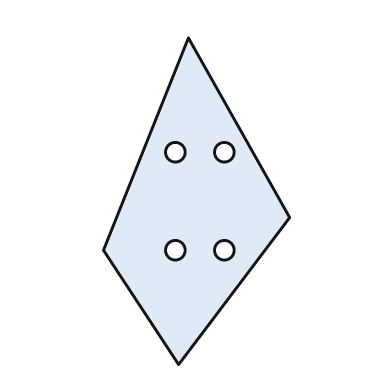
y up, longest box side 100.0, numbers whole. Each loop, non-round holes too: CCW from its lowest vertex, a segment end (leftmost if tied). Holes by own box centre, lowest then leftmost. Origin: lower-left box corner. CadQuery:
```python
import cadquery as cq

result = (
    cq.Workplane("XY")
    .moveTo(23.0, 0.0)
    .lineTo(57.0, 45.0)
    .lineTo(26.0, 100.0)
    .lineTo(0.0, 35.0)
    .close()
    .moveTo(22.0, 35.0)
    .circle(3.0)
    .moveTo(37.0, 35.0)
    .circle(3.0)
    .moveTo(22.0, 65.0)
    .circle(3.0)
    .moveTo(37.0, 65.0)
    .circle(3.0)
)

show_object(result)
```